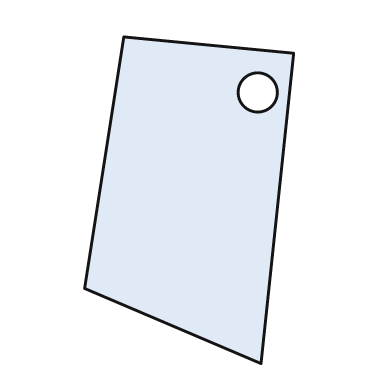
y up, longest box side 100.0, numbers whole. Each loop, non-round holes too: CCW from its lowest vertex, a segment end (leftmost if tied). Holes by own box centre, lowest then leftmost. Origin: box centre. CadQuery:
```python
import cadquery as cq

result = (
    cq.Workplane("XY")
    .moveTo(22.0, -50.0)
    .lineTo(32.0, 45.0)
    .lineTo(-20.0, 50.0)
    .lineTo(-32.0, -27.0)
    .close()
    .moveTo(21.0, 33.0)
    .circle(6.0)
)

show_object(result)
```